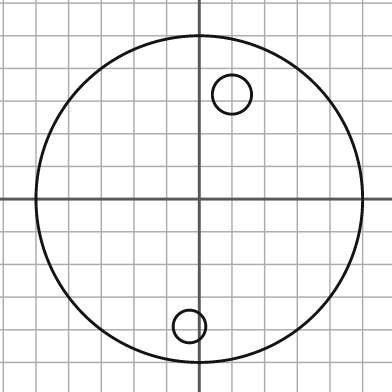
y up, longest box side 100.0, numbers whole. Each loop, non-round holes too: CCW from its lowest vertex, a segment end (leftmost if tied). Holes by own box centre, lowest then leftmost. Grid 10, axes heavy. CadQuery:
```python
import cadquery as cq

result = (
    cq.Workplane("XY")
    .moveTo(0.0, 0.0)
    .circle(50.0)
    .moveTo(-3.0, -39.0)
    .circle(5.0)
    .moveTo(10.0, 32.0)
    .circle(6.0)
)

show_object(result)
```